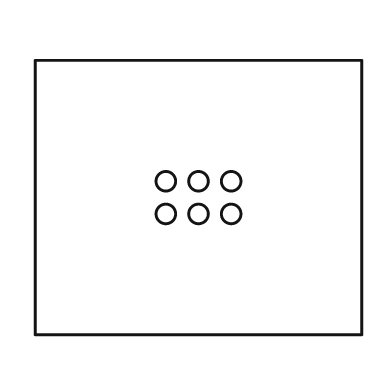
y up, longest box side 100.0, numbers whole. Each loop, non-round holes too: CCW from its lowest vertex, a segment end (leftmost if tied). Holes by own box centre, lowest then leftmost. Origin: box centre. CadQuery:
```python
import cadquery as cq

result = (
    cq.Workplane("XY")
    .moveTo(-50.0, -42.0)
    .lineTo(50.0, -42.0)
    .lineTo(50.0, 42.0)
    .lineTo(-50.0, 42.0)
    .close()
    .moveTo(-10.0, -5.0)
    .circle(3.0)
    .moveTo(0.0, -5.0)
    .circle(3.0)
    .moveTo(10.0, -5.0)
    .circle(3.0)
    .moveTo(-10.0, 5.0)
    .circle(3.0)
    .moveTo(0.0, 5.0)
    .circle(3.0)
    .moveTo(10.0, 5.0)
    .circle(3.0)
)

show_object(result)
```